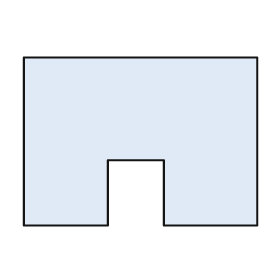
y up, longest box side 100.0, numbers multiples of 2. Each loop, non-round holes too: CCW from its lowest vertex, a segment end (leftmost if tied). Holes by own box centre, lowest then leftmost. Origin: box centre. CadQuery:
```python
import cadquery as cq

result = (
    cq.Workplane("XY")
    .moveTo(-50.0, -36.0)
    .lineTo(-14.0, -36.0)
    .lineTo(-14.0, -8.0)
    .lineTo(10.0, -8.0)
    .lineTo(10.0, -36.0)
    .lineTo(50.0, -36.0)
    .lineTo(50.0, 36.0)
    .lineTo(-50.0, 36.0)
    .close()
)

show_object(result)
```